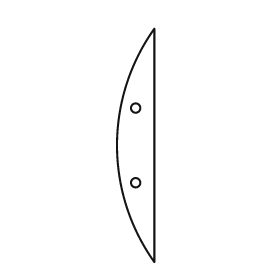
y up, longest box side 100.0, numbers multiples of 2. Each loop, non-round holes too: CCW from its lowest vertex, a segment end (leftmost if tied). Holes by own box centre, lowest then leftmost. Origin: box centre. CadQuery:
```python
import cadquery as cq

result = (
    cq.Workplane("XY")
    .moveTo(8.0, -50.0)
    .lineTo(8.0, 50.0)
    .threePointArc((-8.0, 0.0), (8.0, -50.0))
    .close()
    .moveTo(0.0, -16.0)
    .circle(2.0)
    .moveTo(0.0, 16.0)
    .circle(2.0)
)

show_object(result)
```